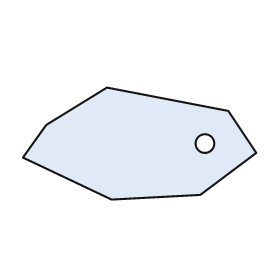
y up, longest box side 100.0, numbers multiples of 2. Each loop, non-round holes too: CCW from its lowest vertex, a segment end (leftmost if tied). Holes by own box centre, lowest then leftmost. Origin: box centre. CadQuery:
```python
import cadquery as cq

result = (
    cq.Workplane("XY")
    .moveTo(-12.0, -24.0)
    .lineTo(26.0, -22.0)
    .lineTo(50.0, -4.0)
    .lineTo(38.0, 14.0)
    .lineTo(-14.0, 24.0)
    .lineTo(-40.0, 8.0)
    .lineTo(-50.0, -6.0)
    .close()
    .moveTo(28.0, 0.0)
    .circle(4.0)
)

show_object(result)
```